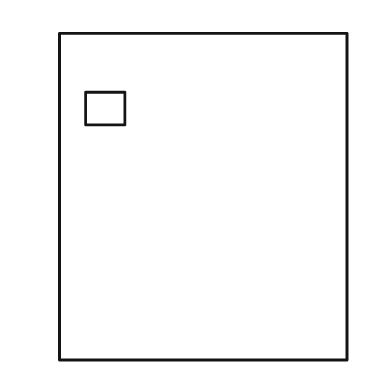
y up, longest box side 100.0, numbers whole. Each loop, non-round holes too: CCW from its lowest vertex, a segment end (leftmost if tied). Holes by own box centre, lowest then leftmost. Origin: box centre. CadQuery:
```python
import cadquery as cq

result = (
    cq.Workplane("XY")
    .moveTo(-44.0, -50.0)
    .lineTo(44.0, -50.0)
    .lineTo(44.0, 50.0)
    .lineTo(-44.0, 50.0)
    .close()
    .moveTo(-36.0, 22.0)
    .lineTo(-24.0, 22.0)
    .lineTo(-24.0, 32.0)
    .lineTo(-36.0, 32.0)
    .close()
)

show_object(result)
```